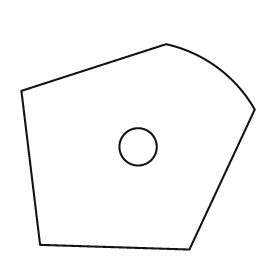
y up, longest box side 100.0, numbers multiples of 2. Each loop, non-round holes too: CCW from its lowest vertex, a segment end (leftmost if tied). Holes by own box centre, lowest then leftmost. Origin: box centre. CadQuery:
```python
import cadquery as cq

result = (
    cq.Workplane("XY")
    .moveTo(22.0, -44.0)
    .lineTo(50.0, 16.0)
    .threePointArc((34.0, 34.0), (12.0, 44.0))
    .lineTo(-50.0, 24.0)
    .lineTo(-42.0, -42.0)
    .close()
    .moveTo(0.0, 0.0)
    .circle(8.0)
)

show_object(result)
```